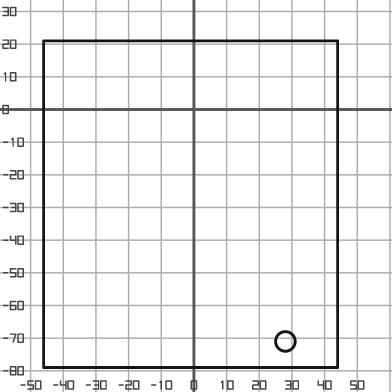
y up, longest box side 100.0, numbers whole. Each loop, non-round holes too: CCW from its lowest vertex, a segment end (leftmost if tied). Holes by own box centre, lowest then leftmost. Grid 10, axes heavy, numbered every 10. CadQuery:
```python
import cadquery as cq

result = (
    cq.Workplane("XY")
    .moveTo(-46.0, -79.0)
    .lineTo(44.0, -79.0)
    .lineTo(44.0, 21.0)
    .lineTo(-46.0, 21.0)
    .close()
    .moveTo(28.0, -71.0)
    .circle(3.0)
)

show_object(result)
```